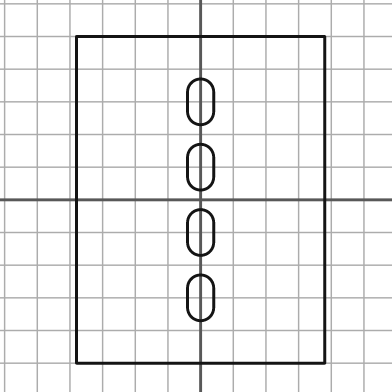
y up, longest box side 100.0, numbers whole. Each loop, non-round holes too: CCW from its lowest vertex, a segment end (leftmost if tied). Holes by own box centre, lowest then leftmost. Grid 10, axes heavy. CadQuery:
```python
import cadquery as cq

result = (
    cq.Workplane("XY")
    .moveTo(-38.0, -50.0)
    .lineTo(38.0, -50.0)
    .lineTo(38.0, 50.0)
    .lineTo(-38.0, 50.0)
    .close()
    .moveTo(-4.0, -33.0)
    .threePointArc((0.0, -37.0), (4.0, -33.0))
    .lineTo(4.0, -27.0)
    .threePointArc((0.0, -23.0), (-4.0, -27.0))
    .close()
    .moveTo(-4.0, -13.0)
    .threePointArc((0.0, -17.0), (4.0, -13.0))
    .lineTo(4.0, -7.0)
    .threePointArc((0.0, -3.0), (-4.0, -7.0))
    .close()
    .moveTo(-4.0, 7.0)
    .threePointArc((0.0, 3.0), (4.0, 7.0))
    .lineTo(4.0, 13.0)
    .threePointArc((0.0, 17.0), (-4.0, 13.0))
    .close()
    .moveTo(-4.0, 27.0)
    .threePointArc((0.0, 23.0), (4.0, 27.0))
    .lineTo(4.0, 33.0)
    .threePointArc((0.0, 37.0), (-4.0, 33.0))
    .close()
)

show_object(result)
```